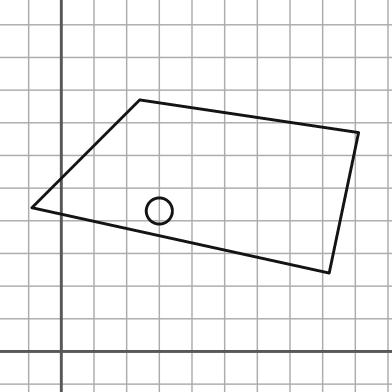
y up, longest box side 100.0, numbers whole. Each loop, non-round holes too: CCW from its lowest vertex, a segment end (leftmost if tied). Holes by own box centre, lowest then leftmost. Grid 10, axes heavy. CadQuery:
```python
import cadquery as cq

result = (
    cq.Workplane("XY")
    .moveTo(82.0, 24.0)
    .lineTo(91.0, 67.0)
    .lineTo(24.0, 77.0)
    .lineTo(-9.0, 44.0)
    .close()
    .moveTo(30.0, 43.0)
    .circle(4.0)
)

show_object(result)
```